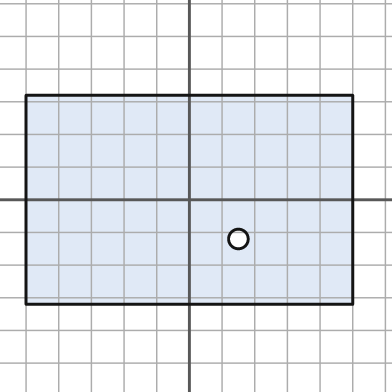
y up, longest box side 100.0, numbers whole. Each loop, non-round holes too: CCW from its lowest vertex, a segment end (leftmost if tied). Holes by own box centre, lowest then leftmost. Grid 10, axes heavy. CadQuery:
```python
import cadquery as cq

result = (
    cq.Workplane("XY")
    .moveTo(-50.0, -32.0)
    .lineTo(50.0, -32.0)
    .lineTo(50.0, 32.0)
    .lineTo(-50.0, 32.0)
    .close()
    .moveTo(15.0, -12.0)
    .circle(3.0)
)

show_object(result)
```